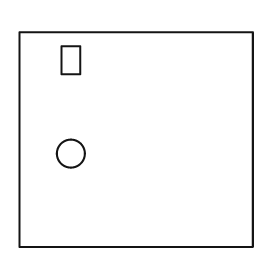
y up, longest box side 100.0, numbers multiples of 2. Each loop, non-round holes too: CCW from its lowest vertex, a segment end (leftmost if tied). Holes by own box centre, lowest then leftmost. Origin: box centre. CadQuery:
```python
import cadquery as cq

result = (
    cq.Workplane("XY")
    .moveTo(-50.0, -46.0)
    .lineTo(50.0, -46.0)
    .lineTo(50.0, 46.0)
    .lineTo(-50.0, 46.0)
    .close()
    .moveTo(-28.0, -6.0)
    .circle(6.0)
    .moveTo(-32.0, 28.0)
    .lineTo(-24.0, 28.0)
    .lineTo(-24.0, 40.0)
    .lineTo(-32.0, 40.0)
    .close()
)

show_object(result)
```